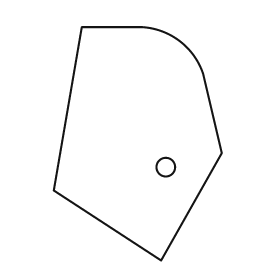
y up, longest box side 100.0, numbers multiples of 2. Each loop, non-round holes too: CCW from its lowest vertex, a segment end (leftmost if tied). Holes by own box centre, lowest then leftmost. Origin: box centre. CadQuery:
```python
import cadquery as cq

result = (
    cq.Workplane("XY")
    .moveTo(10.0, -50.0)
    .lineTo(36.0, -4.0)
    .lineTo(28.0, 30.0)
    .threePointArc((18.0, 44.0), (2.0, 50.0))
    .lineTo(-24.0, 50.0)
    .lineTo(-36.0, -20.0)
    .close()
    .moveTo(12.0, -10.0)
    .circle(4.0)
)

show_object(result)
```